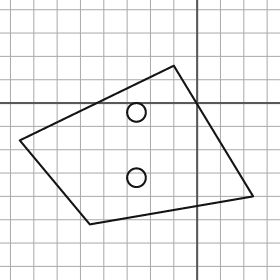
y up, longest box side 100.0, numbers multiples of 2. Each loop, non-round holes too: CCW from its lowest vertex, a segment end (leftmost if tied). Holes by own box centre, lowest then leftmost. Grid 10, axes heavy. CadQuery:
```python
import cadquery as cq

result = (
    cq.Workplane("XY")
    .moveTo(-46.0, -52.0)
    .lineTo(24.0, -40.0)
    .lineTo(-10.0, 16.0)
    .lineTo(-76.0, -16.0)
    .close()
    .moveTo(-26.0, -32.0)
    .circle(4.0)
    .moveTo(-26.0, -4.0)
    .circle(4.0)
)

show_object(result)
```